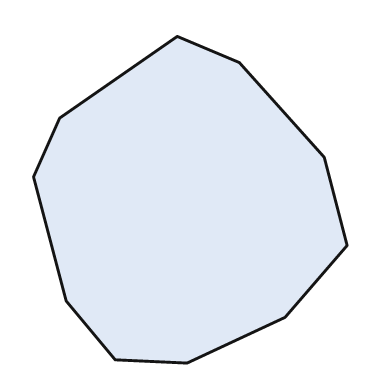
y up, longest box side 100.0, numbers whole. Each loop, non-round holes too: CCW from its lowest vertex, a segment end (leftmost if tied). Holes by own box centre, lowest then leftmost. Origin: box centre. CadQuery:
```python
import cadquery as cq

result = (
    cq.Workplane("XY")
    .moveTo(-1.0, -50.0)
    .lineTo(29.0, -36.0)
    .lineTo(48.0, -14.0)
    .lineTo(41.0, 13.0)
    .lineTo(15.0, 42.0)
    .lineTo(-4.0, 50.0)
    .lineTo(-40.0, 25.0)
    .lineTo(-48.0, 7.0)
    .lineTo(-38.0, -31.0)
    .lineTo(-23.0, -49.0)
    .close()
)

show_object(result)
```